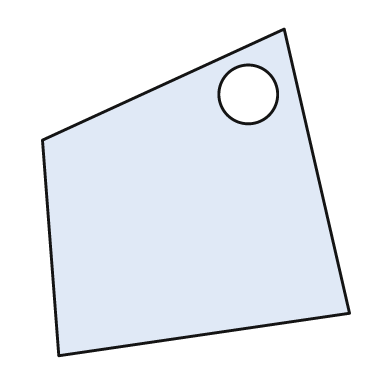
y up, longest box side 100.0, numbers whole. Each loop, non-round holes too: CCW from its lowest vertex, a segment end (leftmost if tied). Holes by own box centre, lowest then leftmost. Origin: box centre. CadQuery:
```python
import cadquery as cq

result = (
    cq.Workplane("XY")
    .moveTo(-42.0, -50.0)
    .lineTo(47.0, -37.0)
    .lineTo(27.0, 50.0)
    .lineTo(-47.0, 16.0)
    .close()
    .moveTo(16.0, 30.0)
    .circle(9.0)
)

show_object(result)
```